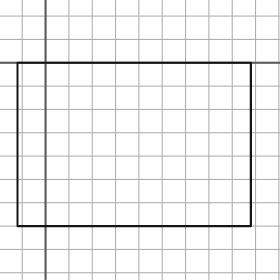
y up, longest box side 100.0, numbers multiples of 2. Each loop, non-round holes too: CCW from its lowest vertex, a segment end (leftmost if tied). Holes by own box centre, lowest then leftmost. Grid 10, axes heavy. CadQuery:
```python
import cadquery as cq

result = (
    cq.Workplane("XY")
    .moveTo(-12.0, -70.0)
    .lineTo(88.0, -70.0)
    .lineTo(88.0, 0.0)
    .lineTo(-12.0, 0.0)
    .close()
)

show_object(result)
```